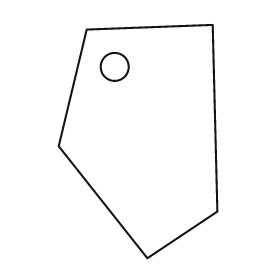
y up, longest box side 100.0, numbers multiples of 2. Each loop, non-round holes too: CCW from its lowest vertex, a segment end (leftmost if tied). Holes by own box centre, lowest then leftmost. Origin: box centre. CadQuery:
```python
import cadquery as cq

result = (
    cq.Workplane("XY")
    .moveTo(4.0, -50.0)
    .lineTo(34.0, -30.0)
    .lineTo(32.0, 50.0)
    .lineTo(-22.0, 48.0)
    .lineTo(-34.0, -2.0)
    .close()
    .moveTo(-10.0, 32.0)
    .circle(6.0)
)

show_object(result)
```